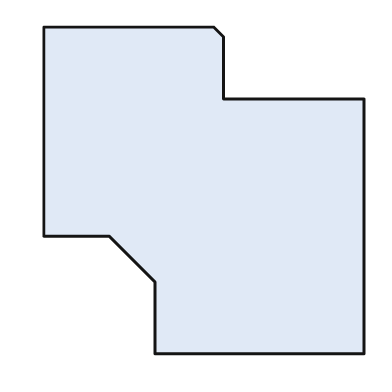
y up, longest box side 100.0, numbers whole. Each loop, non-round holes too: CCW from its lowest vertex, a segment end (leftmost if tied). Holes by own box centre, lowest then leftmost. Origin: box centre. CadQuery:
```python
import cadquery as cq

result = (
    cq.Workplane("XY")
    .moveTo(-15.0, -50.0)
    .lineTo(49.0, -50.0)
    .lineTo(49.0, 28.0)
    .lineTo(6.0, 28.0)
    .lineTo(6.0, 47.0)
    .lineTo(3.0, 50.0)
    .lineTo(-49.0, 50.0)
    .lineTo(-49.0, -14.0)
    .lineTo(-29.0, -14.0)
    .lineTo(-15.0, -28.0)
    .close()
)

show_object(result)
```